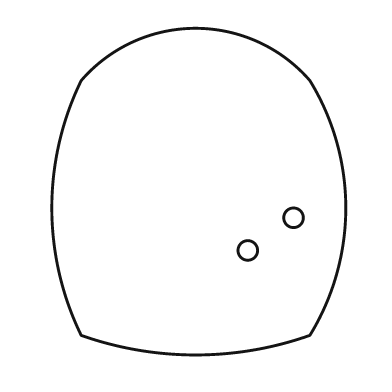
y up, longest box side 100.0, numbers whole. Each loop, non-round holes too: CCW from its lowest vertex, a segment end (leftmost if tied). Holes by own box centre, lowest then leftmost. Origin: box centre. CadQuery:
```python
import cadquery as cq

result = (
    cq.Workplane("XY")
    .moveTo(-36.0, -44.0)
    .threePointArc((-1.0, -50.0), (34.0, -44.0))
    .threePointArc((45.0, -5.0), (34.0, 34.0))
    .threePointArc((-1.0, 50.0), (-36.0, 34.0))
    .threePointArc((-45.0, -5.0), (-36.0, -44.0))
    .close()
    .moveTo(15.0, -18.0)
    .circle(3.0)
    .moveTo(29.0, -8.0)
    .circle(3.0)
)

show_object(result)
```